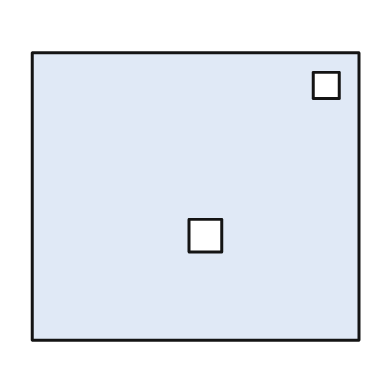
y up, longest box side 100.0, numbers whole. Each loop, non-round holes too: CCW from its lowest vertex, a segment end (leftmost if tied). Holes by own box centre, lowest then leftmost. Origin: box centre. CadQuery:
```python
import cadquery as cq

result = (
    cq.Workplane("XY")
    .moveTo(-50.0, -44.0)
    .lineTo(50.0, -44.0)
    .lineTo(50.0, 44.0)
    .lineTo(-50.0, 44.0)
    .close()
    .moveTo(-2.0, -17.0)
    .lineTo(8.0, -17.0)
    .lineTo(8.0, -7.0)
    .lineTo(-2.0, -7.0)
    .close()
    .moveTo(36.0, 30.0)
    .lineTo(44.0, 30.0)
    .lineTo(44.0, 38.0)
    .lineTo(36.0, 38.0)
    .close()
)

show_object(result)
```